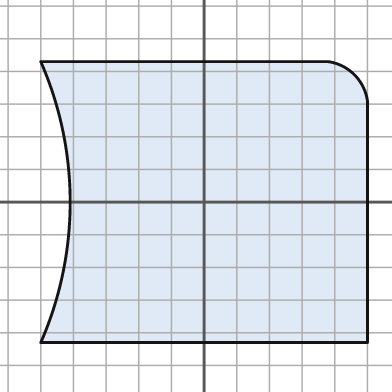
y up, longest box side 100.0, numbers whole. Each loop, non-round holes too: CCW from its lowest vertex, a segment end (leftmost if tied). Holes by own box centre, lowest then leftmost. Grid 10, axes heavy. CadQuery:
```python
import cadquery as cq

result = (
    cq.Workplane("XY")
    .moveTo(-50.0, -43.0)
    .lineTo(50.0, -43.0)
    .lineTo(50.0, 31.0)
    .threePointArc((46.0, 39.0), (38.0, 43.0))
    .lineTo(-50.0, 43.0)
    .threePointArc((-41.0, 0.0), (-50.0, -43.0))
    .close()
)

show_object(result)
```